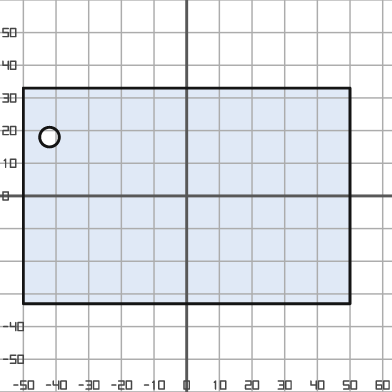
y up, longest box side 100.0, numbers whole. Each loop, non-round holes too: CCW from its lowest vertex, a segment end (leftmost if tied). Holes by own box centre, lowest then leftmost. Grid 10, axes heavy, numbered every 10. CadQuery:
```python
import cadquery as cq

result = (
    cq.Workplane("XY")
    .moveTo(-50.0, -33.0)
    .lineTo(50.0, -33.0)
    .lineTo(50.0, 33.0)
    .lineTo(-50.0, 33.0)
    .close()
    .moveTo(-42.0, 18.0)
    .circle(3.0)
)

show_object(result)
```